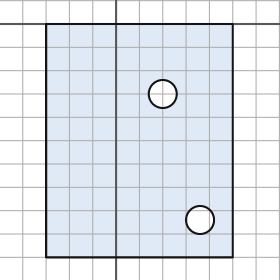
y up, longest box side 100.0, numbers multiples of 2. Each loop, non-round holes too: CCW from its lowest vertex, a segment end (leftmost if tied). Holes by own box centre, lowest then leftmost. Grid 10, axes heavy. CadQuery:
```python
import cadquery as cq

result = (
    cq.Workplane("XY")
    .moveTo(-30.0, -100.0)
    .lineTo(50.0, -100.0)
    .lineTo(50.0, 0.0)
    .lineTo(-30.0, 0.0)
    .close()
    .moveTo(36.0, -84.0)
    .circle(6.0)
    .moveTo(20.0, -30.0)
    .circle(6.0)
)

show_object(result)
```